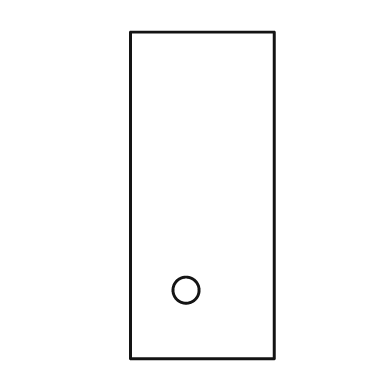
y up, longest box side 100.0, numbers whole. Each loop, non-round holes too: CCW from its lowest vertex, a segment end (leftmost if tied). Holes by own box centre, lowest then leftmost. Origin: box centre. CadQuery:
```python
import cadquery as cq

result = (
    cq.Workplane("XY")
    .moveTo(-22.0, -50.0)
    .lineTo(22.0, -50.0)
    .lineTo(22.0, 50.0)
    .lineTo(-22.0, 50.0)
    .close()
    .moveTo(-5.0, -29.0)
    .circle(4.0)
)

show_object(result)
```